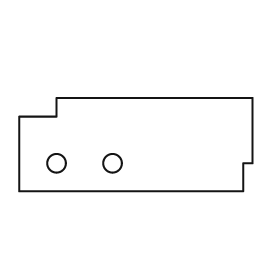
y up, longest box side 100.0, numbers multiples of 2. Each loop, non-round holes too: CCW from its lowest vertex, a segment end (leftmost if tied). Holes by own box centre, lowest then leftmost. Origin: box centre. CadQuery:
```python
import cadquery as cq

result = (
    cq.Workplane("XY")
    .moveTo(-50.0, -20.0)
    .lineTo(46.0, -20.0)
    .lineTo(46.0, -8.0)
    .lineTo(50.0, -8.0)
    .lineTo(50.0, 20.0)
    .lineTo(-34.0, 20.0)
    .lineTo(-34.0, 12.0)
    .lineTo(-50.0, 12.0)
    .close()
    .moveTo(-34.0, -8.0)
    .circle(4.0)
    .moveTo(-10.0, -8.0)
    .circle(4.0)
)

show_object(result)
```